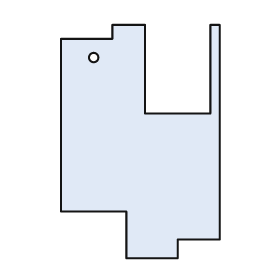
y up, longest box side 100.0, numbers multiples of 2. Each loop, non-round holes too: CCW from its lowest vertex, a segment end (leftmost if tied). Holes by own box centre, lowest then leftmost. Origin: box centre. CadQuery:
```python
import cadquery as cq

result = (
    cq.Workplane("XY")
    .moveTo(-6.0, -50.0)
    .lineTo(16.0, -50.0)
    .lineTo(16.0, -42.0)
    .lineTo(34.0, -42.0)
    .lineTo(34.0, 50.0)
    .lineTo(30.0, 50.0)
    .lineTo(30.0, 12.0)
    .lineTo(2.0, 12.0)
    .lineTo(2.0, 50.0)
    .lineTo(-12.0, 50.0)
    .lineTo(-12.0, 44.0)
    .lineTo(-34.0, 44.0)
    .lineTo(-34.0, -30.0)
    .lineTo(-6.0, -30.0)
    .close()
    .moveTo(-20.0, 36.0)
    .circle(2.0)
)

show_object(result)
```